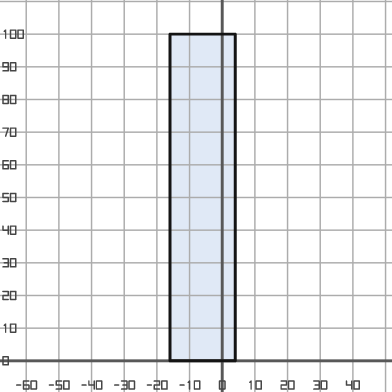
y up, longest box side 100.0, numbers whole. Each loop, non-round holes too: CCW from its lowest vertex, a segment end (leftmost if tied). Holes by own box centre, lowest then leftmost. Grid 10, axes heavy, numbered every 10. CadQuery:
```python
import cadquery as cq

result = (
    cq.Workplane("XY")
    .moveTo(-16.0, 0.0)
    .lineTo(4.0, 0.0)
    .lineTo(4.0, 100.0)
    .lineTo(-16.0, 100.0)
    .close()
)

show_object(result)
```